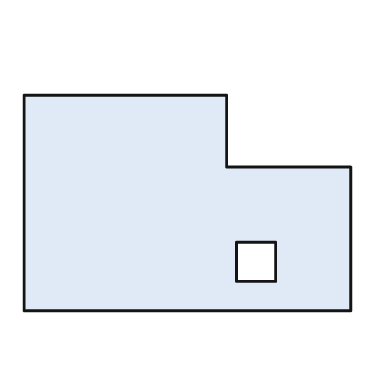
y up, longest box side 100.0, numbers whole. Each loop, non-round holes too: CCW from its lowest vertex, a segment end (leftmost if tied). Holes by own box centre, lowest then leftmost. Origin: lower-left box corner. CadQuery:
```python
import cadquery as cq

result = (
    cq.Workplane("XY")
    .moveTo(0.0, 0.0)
    .lineTo(100.0, 0.0)
    .lineTo(100.0, 44.0)
    .lineTo(62.0, 44.0)
    .lineTo(62.0, 66.0)
    .lineTo(0.0, 66.0)
    .close()
    .moveTo(65.0, 9.0)
    .lineTo(77.0, 9.0)
    .lineTo(77.0, 21.0)
    .lineTo(65.0, 21.0)
    .close()
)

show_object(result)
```